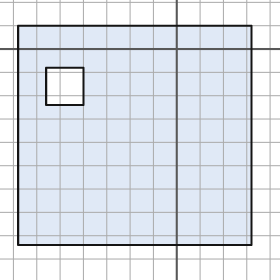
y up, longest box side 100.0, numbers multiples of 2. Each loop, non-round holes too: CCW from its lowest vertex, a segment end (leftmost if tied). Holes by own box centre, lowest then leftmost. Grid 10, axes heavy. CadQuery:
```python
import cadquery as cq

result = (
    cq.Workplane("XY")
    .moveTo(-68.0, -84.0)
    .lineTo(32.0, -84.0)
    .lineTo(32.0, 10.0)
    .lineTo(-68.0, 10.0)
    .close()
    .moveTo(-56.0, -24.0)
    .lineTo(-40.0, -24.0)
    .lineTo(-40.0, -8.0)
    .lineTo(-56.0, -8.0)
    .close()
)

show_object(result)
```